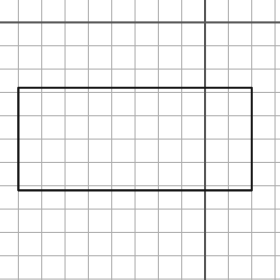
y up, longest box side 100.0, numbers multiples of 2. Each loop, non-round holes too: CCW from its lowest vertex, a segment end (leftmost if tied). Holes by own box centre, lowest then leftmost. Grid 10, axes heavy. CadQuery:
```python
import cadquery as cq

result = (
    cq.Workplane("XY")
    .moveTo(-80.0, -72.0)
    .lineTo(20.0, -72.0)
    .lineTo(20.0, -28.0)
    .lineTo(-80.0, -28.0)
    .close()
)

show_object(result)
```